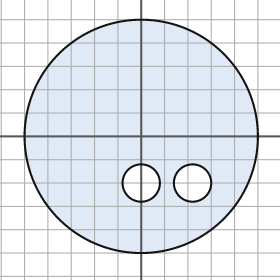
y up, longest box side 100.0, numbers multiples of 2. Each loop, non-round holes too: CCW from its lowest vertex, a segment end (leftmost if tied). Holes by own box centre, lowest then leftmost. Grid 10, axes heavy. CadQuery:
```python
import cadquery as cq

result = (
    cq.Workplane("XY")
    .moveTo(0.0, 0.0)
    .circle(50.0)
    .moveTo(0.0, -20.0)
    .circle(8.0)
    .moveTo(22.0, -20.0)
    .circle(8.0)
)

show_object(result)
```